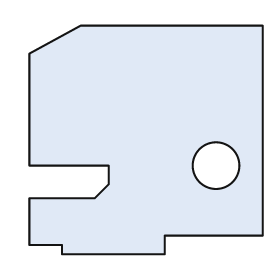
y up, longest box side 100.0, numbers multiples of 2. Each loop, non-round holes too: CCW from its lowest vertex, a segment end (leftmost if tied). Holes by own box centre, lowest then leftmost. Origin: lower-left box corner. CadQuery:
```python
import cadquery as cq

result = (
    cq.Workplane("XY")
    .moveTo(14.0, 0.0)
    .lineTo(58.0, 0.0)
    .lineTo(58.0, 8.0)
    .lineTo(100.0, 8.0)
    .lineTo(100.0, 98.0)
    .lineTo(22.0, 98.0)
    .lineTo(0.0, 86.0)
    .lineTo(0.0, 38.0)
    .lineTo(34.0, 38.0)
    .lineTo(34.0, 30.0)
    .lineTo(28.0, 24.0)
    .lineTo(0.0, 24.0)
    .lineTo(0.0, 4.0)
    .lineTo(14.0, 4.0)
    .close()
    .moveTo(80.0, 38.0)
    .circle(10.0)
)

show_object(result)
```